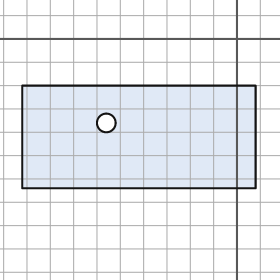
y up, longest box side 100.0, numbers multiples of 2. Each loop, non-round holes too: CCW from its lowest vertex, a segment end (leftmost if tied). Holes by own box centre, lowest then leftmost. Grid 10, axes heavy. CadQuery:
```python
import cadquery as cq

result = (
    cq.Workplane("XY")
    .moveTo(-92.0, -64.0)
    .lineTo(8.0, -64.0)
    .lineTo(8.0, -20.0)
    .lineTo(-92.0, -20.0)
    .close()
    .moveTo(-56.0, -36.0)
    .circle(4.0)
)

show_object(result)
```